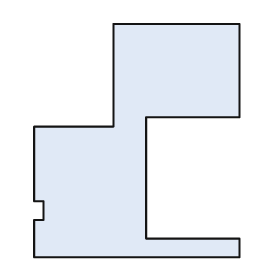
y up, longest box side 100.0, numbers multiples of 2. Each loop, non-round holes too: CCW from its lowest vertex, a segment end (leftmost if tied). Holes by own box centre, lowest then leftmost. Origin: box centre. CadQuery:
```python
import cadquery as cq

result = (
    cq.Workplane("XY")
    .moveTo(-44.0, -50.0)
    .lineTo(44.0, -50.0)
    .lineTo(44.0, -42.0)
    .lineTo(4.0, -42.0)
    .lineTo(4.0, 10.0)
    .lineTo(44.0, 10.0)
    .lineTo(44.0, 50.0)
    .lineTo(-10.0, 50.0)
    .lineTo(-10.0, 6.0)
    .lineTo(-44.0, 6.0)
    .lineTo(-44.0, -26.0)
    .lineTo(-40.0, -26.0)
    .lineTo(-40.0, -34.0)
    .lineTo(-44.0, -34.0)
    .close()
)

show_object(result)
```